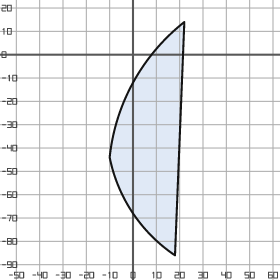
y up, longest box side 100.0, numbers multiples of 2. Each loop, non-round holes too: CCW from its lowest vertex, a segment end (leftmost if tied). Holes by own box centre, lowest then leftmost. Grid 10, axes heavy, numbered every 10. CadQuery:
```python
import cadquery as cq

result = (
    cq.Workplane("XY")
    .moveTo(18.0, -86.0)
    .lineTo(22.0, 14.0)
    .threePointArc((0.0, -12.0), (-10.0, -44.0))
    .threePointArc((0.0, -68.0), (18.0, -86.0))
    .close()
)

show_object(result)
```